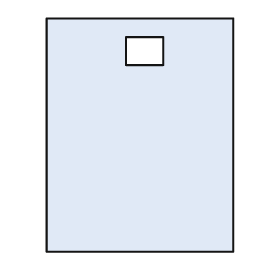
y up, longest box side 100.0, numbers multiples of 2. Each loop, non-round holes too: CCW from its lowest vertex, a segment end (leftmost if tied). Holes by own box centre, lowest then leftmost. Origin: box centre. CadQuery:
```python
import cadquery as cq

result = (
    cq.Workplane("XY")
    .moveTo(-40.0, -50.0)
    .lineTo(40.0, -50.0)
    .lineTo(40.0, 50.0)
    .lineTo(-40.0, 50.0)
    .close()
    .moveTo(-6.0, 30.0)
    .lineTo(10.0, 30.0)
    .lineTo(10.0, 42.0)
    .lineTo(-6.0, 42.0)
    .close()
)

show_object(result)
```